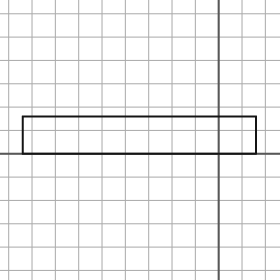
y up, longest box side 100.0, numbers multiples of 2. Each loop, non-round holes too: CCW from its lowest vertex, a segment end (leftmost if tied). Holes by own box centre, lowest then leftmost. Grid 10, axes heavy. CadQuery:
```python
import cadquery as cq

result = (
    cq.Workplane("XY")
    .moveTo(-84.0, 0.0)
    .lineTo(16.0, 0.0)
    .lineTo(16.0, 16.0)
    .lineTo(-84.0, 16.0)
    .close()
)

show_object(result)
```